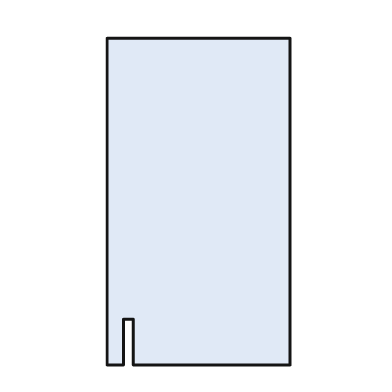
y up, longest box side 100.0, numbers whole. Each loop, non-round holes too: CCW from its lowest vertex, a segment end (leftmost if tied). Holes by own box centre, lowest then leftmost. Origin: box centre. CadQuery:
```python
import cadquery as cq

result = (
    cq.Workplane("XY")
    .moveTo(-28.0, -50.0)
    .lineTo(-23.0, -50.0)
    .lineTo(-23.0, -36.0)
    .lineTo(-20.0, -36.0)
    .lineTo(-20.0, -50.0)
    .lineTo(28.0, -50.0)
    .lineTo(28.0, 50.0)
    .lineTo(-28.0, 50.0)
    .close()
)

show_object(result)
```